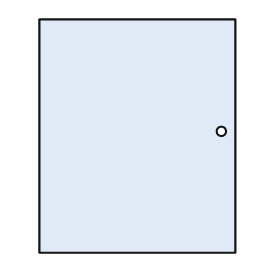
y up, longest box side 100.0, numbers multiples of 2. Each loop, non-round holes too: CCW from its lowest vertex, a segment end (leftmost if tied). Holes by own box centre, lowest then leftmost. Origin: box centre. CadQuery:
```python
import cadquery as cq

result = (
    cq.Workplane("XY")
    .moveTo(-42.0, -50.0)
    .lineTo(42.0, -50.0)
    .lineTo(42.0, 50.0)
    .lineTo(-42.0, 50.0)
    .close()
    .moveTo(36.0, 2.0)
    .circle(2.0)
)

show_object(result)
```